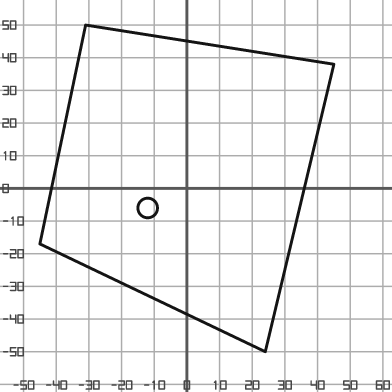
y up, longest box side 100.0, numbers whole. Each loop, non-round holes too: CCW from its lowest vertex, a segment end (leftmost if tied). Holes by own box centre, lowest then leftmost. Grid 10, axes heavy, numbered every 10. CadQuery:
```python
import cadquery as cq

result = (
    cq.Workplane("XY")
    .moveTo(24.0, -50.0)
    .lineTo(45.0, 38.0)
    .lineTo(-31.0, 50.0)
    .lineTo(-45.0, -17.0)
    .close()
    .moveTo(-12.0, -6.0)
    .circle(3.0)
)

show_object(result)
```